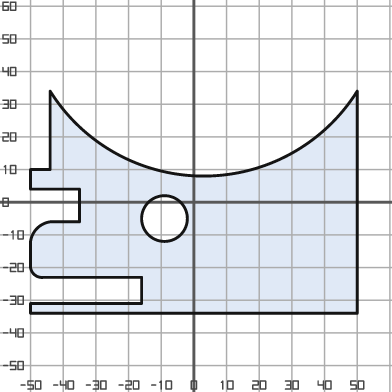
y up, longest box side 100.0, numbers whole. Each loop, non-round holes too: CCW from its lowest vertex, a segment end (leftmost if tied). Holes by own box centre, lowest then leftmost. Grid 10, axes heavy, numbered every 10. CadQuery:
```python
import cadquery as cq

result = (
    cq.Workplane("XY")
    .moveTo(-50.0, -34.0)
    .lineTo(50.0, -34.0)
    .lineTo(50.0, 34.0)
    .threePointArc((3.0, 8.0), (-44.0, 34.0))
    .lineTo(-44.0, 10.0)
    .lineTo(-50.0, 10.0)
    .lineTo(-50.0, 4.0)
    .lineTo(-35.0, 4.0)
    .lineTo(-35.0, -6.0)
    .lineTo(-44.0, -6.0)
    .threePointArc((-48.0, -8.0), (-50.0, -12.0))
    .lineTo(-50.0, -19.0)
    .threePointArc((-49.0, -22.0), (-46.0, -23.0))
    .lineTo(-16.0, -23.0)
    .lineTo(-16.0, -31.0)
    .lineTo(-50.0, -31.0)
    .close()
    .moveTo(-9.0, -5.0)
    .circle(7.0)
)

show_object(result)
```